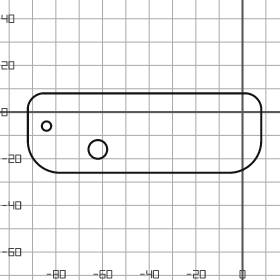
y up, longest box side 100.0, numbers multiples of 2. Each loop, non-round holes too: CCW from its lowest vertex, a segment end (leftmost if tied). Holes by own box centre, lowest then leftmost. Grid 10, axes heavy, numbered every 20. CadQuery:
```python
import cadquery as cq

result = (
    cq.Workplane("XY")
    .moveTo(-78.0, -26.0)
    .lineTo(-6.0, -26.0)
    .threePointArc((4.0, -22.0), (8.0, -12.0))
    .lineTo(8.0, 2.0)
    .threePointArc((6.0, 6.0), (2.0, 8.0))
    .lineTo(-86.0, 8.0)
    .threePointArc((-90.0, 6.0), (-92.0, 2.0))
    .lineTo(-92.0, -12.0)
    .threePointArc((-88.0, -22.0), (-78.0, -26.0))
    .close()
    .moveTo(-62.0, -16.0)
    .circle(4.0)
    .moveTo(-84.0, -6.0)
    .circle(2.0)
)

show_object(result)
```